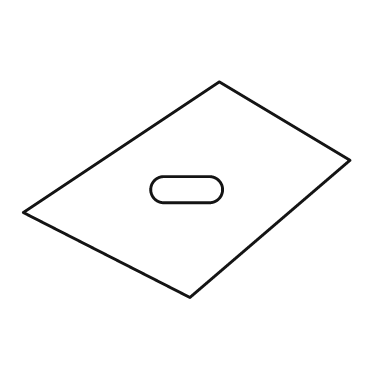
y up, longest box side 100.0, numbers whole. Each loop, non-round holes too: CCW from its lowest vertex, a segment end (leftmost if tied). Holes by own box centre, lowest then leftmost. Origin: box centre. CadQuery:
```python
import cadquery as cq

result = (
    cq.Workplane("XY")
    .moveTo(1.0, -33.0)
    .lineTo(50.0, 9.0)
    .lineTo(10.0, 33.0)
    .lineTo(-50.0, -7.0)
    .close()
    .moveTo(-7.0, -4.0)
    .lineTo(7.0, -4.0)
    .threePointArc((11.0, 0.0), (7.0, 4.0))
    .lineTo(-7.0, 4.0)
    .threePointArc((-11.0, 0.0), (-7.0, -4.0))
    .close()
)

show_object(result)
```